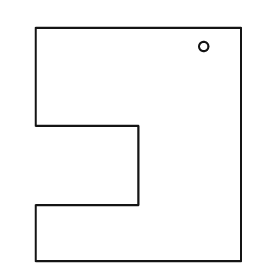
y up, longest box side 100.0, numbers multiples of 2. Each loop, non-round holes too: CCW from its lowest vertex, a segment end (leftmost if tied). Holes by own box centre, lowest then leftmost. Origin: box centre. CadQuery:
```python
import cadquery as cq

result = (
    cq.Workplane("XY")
    .moveTo(-44.0, -50.0)
    .lineTo(44.0, -50.0)
    .lineTo(44.0, 50.0)
    .lineTo(-44.0, 50.0)
    .lineTo(-44.0, 8.0)
    .lineTo(0.0, 8.0)
    .lineTo(0.0, -26.0)
    .lineTo(-44.0, -26.0)
    .close()
    .moveTo(28.0, 42.0)
    .circle(2.0)
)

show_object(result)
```